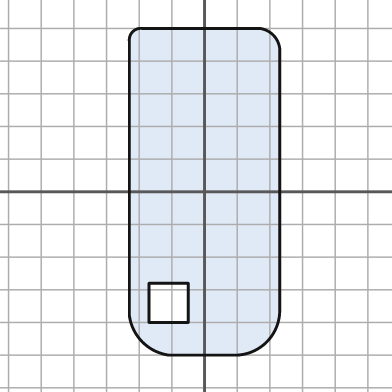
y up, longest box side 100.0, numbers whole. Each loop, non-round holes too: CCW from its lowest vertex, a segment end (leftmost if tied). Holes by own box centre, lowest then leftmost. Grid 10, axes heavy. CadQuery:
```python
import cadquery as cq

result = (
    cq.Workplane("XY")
    .moveTo(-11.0, -50.0)
    .lineTo(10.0, -50.0)
    .threePointArc((19.0, -46.0), (23.0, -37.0))
    .lineTo(23.0, 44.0)
    .threePointArc((21.0, 48.0), (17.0, 50.0))
    .lineTo(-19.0, 50.0)
    .threePointArc((-22.0, 49.0), (-23.0, 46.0))
    .lineTo(-23.0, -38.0)
    .threePointArc((-19.0, -46.0), (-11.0, -50.0))
    .close()
    .moveTo(-17.0, -40.0)
    .lineTo(-5.0, -40.0)
    .lineTo(-5.0, -28.0)
    .lineTo(-17.0, -28.0)
    .close()
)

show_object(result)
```